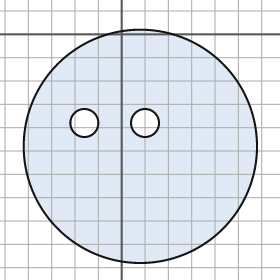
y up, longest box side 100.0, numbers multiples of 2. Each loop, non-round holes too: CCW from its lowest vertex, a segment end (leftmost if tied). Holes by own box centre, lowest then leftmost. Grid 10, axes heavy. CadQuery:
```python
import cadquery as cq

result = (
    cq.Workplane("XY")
    .moveTo(8.0, -48.0)
    .circle(50.0)
    .moveTo(-16.0, -38.0)
    .circle(6.0)
    .moveTo(10.0, -38.0)
    .circle(6.0)
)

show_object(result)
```